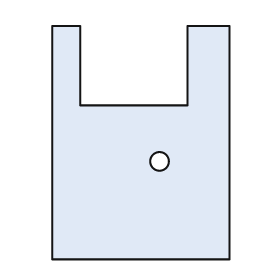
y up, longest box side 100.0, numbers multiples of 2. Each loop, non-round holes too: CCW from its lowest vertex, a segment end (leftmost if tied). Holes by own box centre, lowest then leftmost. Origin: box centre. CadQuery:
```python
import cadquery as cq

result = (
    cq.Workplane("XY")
    .moveTo(-38.0, -50.0)
    .lineTo(38.0, -50.0)
    .lineTo(38.0, 50.0)
    .lineTo(20.0, 50.0)
    .lineTo(20.0, 16.0)
    .lineTo(-26.0, 16.0)
    .lineTo(-26.0, 50.0)
    .lineTo(-38.0, 50.0)
    .close()
    .moveTo(8.0, -8.0)
    .circle(4.0)
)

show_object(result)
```